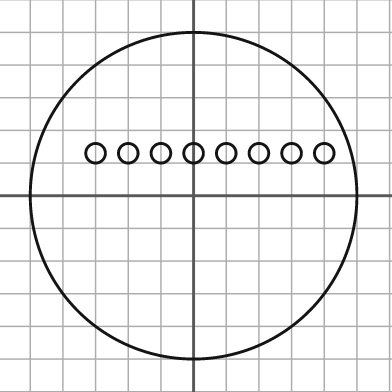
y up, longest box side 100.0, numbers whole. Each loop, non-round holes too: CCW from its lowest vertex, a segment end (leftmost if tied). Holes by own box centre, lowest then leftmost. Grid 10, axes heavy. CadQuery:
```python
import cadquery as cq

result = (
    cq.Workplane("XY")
    .moveTo(0.0, 0.0)
    .circle(50.0)
    .moveTo(-30.0, 13.0)
    .circle(3.0)
    .moveTo(-20.0, 13.0)
    .circle(3.0)
    .moveTo(-10.0, 13.0)
    .circle(3.0)
    .moveTo(0.0, 13.0)
    .circle(3.0)
    .moveTo(10.0, 13.0)
    .circle(3.0)
    .moveTo(20.0, 13.0)
    .circle(3.0)
    .moveTo(30.0, 13.0)
    .circle(3.0)
    .moveTo(40.0, 13.0)
    .circle(3.0)
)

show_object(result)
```